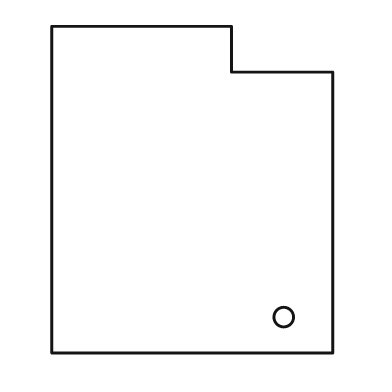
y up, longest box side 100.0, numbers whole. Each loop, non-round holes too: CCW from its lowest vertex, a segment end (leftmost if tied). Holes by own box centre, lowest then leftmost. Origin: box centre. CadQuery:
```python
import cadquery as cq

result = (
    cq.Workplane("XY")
    .moveTo(-43.0, -50.0)
    .lineTo(43.0, -50.0)
    .lineTo(43.0, 36.0)
    .lineTo(12.0, 36.0)
    .lineTo(12.0, 50.0)
    .lineTo(-43.0, 50.0)
    .close()
    .moveTo(28.0, -39.0)
    .circle(3.0)
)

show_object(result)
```